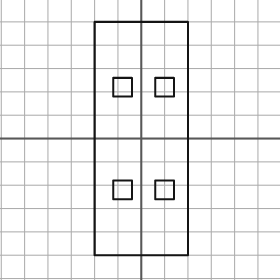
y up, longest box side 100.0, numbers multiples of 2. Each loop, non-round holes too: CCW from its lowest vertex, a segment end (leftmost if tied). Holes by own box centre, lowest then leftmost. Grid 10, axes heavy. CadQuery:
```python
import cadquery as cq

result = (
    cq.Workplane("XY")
    .moveTo(-20.0, -50.0)
    .lineTo(20.0, -50.0)
    .lineTo(20.0, 50.0)
    .lineTo(-20.0, 50.0)
    .close()
    .moveTo(-12.0, -26.0)
    .lineTo(-4.0, -26.0)
    .lineTo(-4.0, -18.0)
    .lineTo(-12.0, -18.0)
    .close()
    .moveTo(6.0, -26.0)
    .lineTo(14.0, -26.0)
    .lineTo(14.0, -18.0)
    .lineTo(6.0, -18.0)
    .close()
    .moveTo(-12.0, 18.0)
    .lineTo(-4.0, 18.0)
    .lineTo(-4.0, 26.0)
    .lineTo(-12.0, 26.0)
    .close()
    .moveTo(6.0, 18.0)
    .lineTo(14.0, 18.0)
    .lineTo(14.0, 26.0)
    .lineTo(6.0, 26.0)
    .close()
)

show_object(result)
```